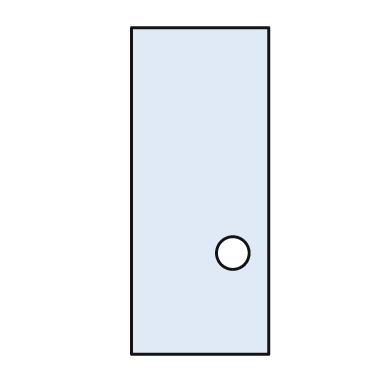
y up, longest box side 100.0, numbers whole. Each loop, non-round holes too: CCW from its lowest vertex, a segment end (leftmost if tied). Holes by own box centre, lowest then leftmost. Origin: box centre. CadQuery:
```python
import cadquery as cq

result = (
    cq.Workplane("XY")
    .moveTo(-21.0, -50.0)
    .lineTo(21.0, -50.0)
    .lineTo(21.0, 50.0)
    .lineTo(-21.0, 50.0)
    .close()
    .moveTo(10.0, -19.0)
    .circle(5.0)
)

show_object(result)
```